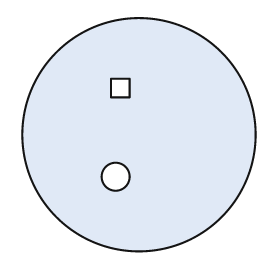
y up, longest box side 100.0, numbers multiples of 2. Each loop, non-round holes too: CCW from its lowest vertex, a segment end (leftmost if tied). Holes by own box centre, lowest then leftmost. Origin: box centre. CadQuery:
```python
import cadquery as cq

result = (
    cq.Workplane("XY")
    .moveTo(0.0, 0.0)
    .circle(50.0)
    .moveTo(-10.0, -18.0)
    .circle(6.0)
    .moveTo(-12.0, 16.0)
    .lineTo(-4.0, 16.0)
    .lineTo(-4.0, 24.0)
    .lineTo(-12.0, 24.0)
    .close()
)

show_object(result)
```